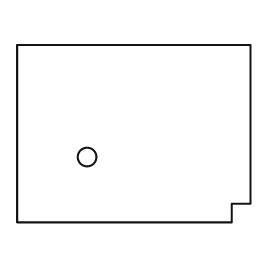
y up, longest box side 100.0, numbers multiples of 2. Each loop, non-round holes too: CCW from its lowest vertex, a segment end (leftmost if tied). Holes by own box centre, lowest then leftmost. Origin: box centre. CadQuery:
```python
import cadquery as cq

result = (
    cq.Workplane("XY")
    .moveTo(-50.0, -38.0)
    .lineTo(42.0, -38.0)
    .lineTo(42.0, -30.0)
    .lineTo(50.0, -30.0)
    .lineTo(50.0, 38.0)
    .lineTo(-50.0, 38.0)
    .close()
    .moveTo(-20.0, -10.0)
    .circle(4.0)
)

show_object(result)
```